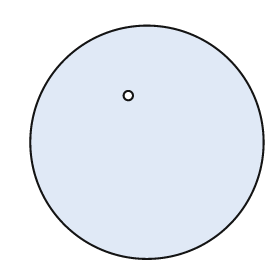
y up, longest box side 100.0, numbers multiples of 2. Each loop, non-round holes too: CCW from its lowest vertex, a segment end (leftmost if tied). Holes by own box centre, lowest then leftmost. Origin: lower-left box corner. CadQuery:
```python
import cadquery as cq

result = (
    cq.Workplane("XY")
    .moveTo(50.0, 50.0)
    .circle(50.0)
    .moveTo(42.0, 70.0)
    .circle(2.0)
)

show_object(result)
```